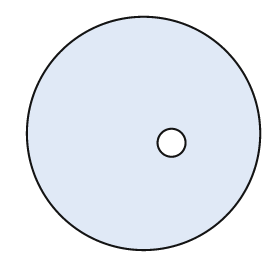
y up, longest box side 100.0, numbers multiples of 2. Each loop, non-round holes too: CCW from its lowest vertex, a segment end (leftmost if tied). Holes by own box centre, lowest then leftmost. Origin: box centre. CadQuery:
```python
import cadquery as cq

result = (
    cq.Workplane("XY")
    .moveTo(0.0, 0.0)
    .circle(50.0)
    .moveTo(12.0, -4.0)
    .circle(6.0)
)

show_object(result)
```